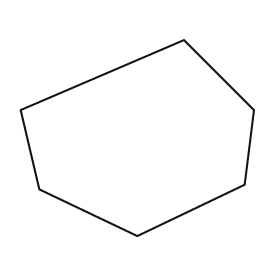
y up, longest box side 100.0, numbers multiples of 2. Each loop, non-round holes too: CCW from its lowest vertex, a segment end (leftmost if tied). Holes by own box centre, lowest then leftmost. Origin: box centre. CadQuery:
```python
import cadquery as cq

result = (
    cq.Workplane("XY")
    .moveTo(0.0, -42.0)
    .lineTo(46.0, -20.0)
    .lineTo(50.0, 12.0)
    .lineTo(20.0, 42.0)
    .lineTo(-50.0, 12.0)
    .lineTo(-42.0, -22.0)
    .close()
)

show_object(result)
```